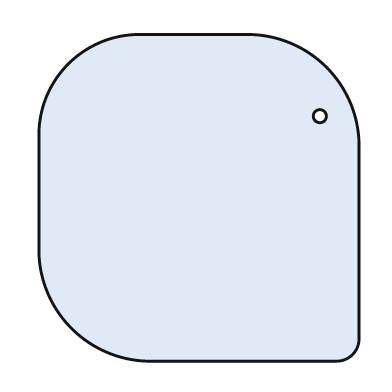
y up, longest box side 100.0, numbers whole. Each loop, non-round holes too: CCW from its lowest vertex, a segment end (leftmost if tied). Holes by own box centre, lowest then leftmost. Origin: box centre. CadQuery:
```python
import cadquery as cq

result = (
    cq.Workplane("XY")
    .moveTo(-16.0, -50.0)
    .lineTo(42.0, -50.0)
    .threePointArc((47.0, -48.0), (49.0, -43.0))
    .lineTo(49.0, 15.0)
    .threePointArc((39.0, 40.0), (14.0, 50.0))
    .lineTo(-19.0, 50.0)
    .threePointArc((-40.0, 41.0), (-49.0, 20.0))
    .lineTo(-49.0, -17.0)
    .threePointArc((-39.0, -40.0), (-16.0, -50.0))
    .close()
    .moveTo(37.0, 25.0)
    .circle(2.0)
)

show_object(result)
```